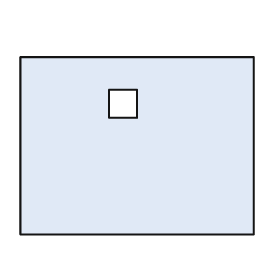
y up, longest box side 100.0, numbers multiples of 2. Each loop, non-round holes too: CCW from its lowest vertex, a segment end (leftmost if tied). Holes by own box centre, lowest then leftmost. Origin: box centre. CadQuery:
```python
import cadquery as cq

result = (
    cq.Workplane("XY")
    .moveTo(-50.0, -38.0)
    .lineTo(50.0, -38.0)
    .lineTo(50.0, 38.0)
    .lineTo(-50.0, 38.0)
    .close()
    .moveTo(-12.0, 12.0)
    .lineTo(0.0, 12.0)
    .lineTo(0.0, 24.0)
    .lineTo(-12.0, 24.0)
    .close()
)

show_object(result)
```